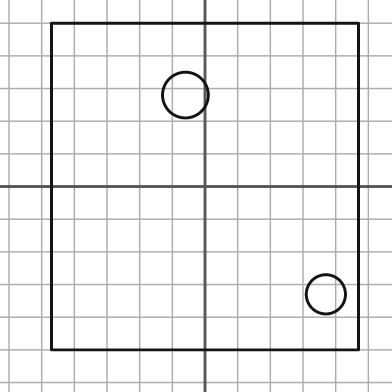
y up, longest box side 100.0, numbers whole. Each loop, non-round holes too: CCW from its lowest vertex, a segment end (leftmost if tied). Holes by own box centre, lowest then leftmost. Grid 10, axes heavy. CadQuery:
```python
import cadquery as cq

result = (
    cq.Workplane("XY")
    .moveTo(-47.0, -50.0)
    .lineTo(47.0, -50.0)
    .lineTo(47.0, 50.0)
    .lineTo(-47.0, 50.0)
    .close()
    .moveTo(37.0, -33.0)
    .circle(6.0)
    .moveTo(-6.0, 28.0)
    .circle(7.0)
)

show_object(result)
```